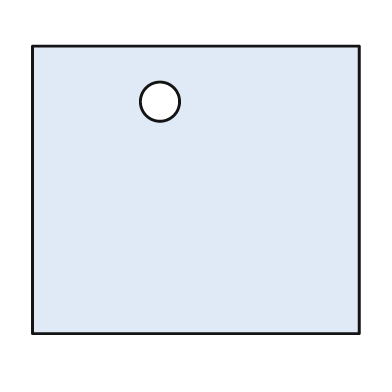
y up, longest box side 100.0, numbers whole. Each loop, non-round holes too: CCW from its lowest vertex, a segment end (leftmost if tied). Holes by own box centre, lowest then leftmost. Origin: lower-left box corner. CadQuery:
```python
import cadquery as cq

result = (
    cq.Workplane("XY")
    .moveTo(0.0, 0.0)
    .lineTo(100.0, 0.0)
    .lineTo(100.0, 88.0)
    .lineTo(0.0, 88.0)
    .close()
    .moveTo(39.0, 71.0)
    .circle(6.0)
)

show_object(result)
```